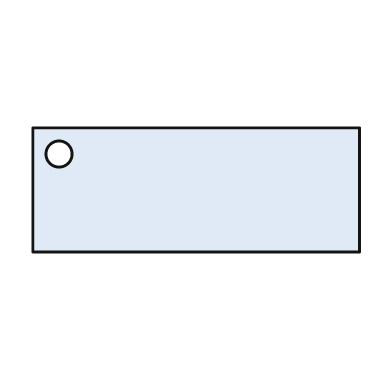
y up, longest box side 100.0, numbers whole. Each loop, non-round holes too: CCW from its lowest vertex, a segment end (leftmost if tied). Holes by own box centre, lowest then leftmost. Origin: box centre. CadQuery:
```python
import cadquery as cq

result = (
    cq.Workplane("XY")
    .moveTo(-50.0, -19.0)
    .lineTo(50.0, -19.0)
    .lineTo(50.0, 19.0)
    .lineTo(-50.0, 19.0)
    .close()
    .moveTo(-42.0, 11.0)
    .circle(4.0)
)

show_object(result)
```